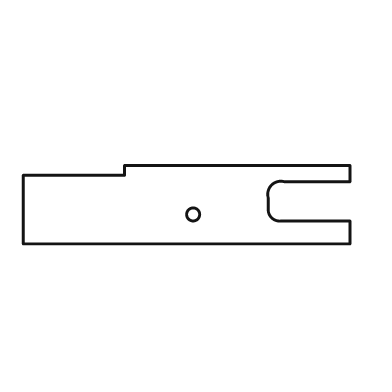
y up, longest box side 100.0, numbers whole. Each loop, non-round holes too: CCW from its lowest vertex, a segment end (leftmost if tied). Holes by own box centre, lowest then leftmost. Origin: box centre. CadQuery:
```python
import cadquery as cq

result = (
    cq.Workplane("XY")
    .moveTo(-50.0, -12.0)
    .lineTo(50.0, -12.0)
    .lineTo(50.0, -5.0)
    .lineTo(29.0, -5.0)
    .threePointArc((26.0, -4.0), (25.0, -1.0))
    .lineTo(25.0, 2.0)
    .threePointArc((26.0, 6.0), (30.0, 7.0))
    .lineTo(50.0, 7.0)
    .lineTo(50.0, 12.0)
    .lineTo(-19.0, 12.0)
    .lineTo(-19.0, 9.0)
    .lineTo(-50.0, 9.0)
    .close()
    .moveTo(2.0, -3.0)
    .circle(2.0)
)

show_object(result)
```